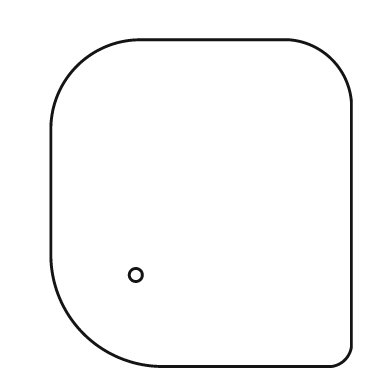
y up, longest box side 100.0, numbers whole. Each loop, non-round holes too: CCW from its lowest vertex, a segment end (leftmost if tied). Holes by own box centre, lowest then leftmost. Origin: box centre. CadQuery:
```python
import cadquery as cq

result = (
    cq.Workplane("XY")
    .moveTo(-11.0, -50.0)
    .lineTo(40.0, -50.0)
    .threePointArc((44.0, -48.0), (46.0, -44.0))
    .lineTo(46.0, 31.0)
    .threePointArc((40.0, 44.0), (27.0, 50.0))
    .lineTo(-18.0, 50.0)
    .threePointArc((-38.0, 42.0), (-46.0, 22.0))
    .lineTo(-46.0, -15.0)
    .threePointArc((-36.0, -40.0), (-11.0, -50.0))
    .close()
    .moveTo(-20.0, -22.0)
    .circle(2.0)
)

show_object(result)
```